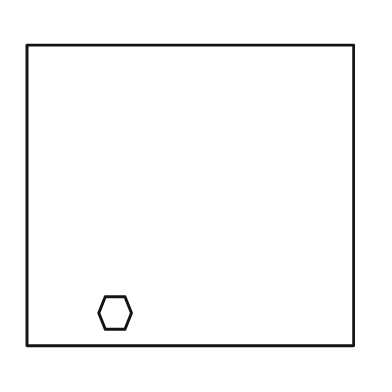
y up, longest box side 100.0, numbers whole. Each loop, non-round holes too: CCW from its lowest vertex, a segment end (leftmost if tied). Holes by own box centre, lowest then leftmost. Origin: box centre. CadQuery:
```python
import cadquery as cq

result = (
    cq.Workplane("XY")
    .moveTo(-50.0, -46.0)
    .lineTo(50.0, -46.0)
    .lineTo(50.0, 46.0)
    .lineTo(-50.0, 46.0)
    .close()
    .moveTo(-26.0, -41.0)
    .lineTo(-20.0, -41.0)
    .lineTo(-18.0, -36.0)
    .lineTo(-20.0, -31.0)
    .lineTo(-26.0, -31.0)
    .lineTo(-28.0, -36.0)
    .close()
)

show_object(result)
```